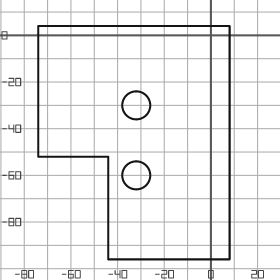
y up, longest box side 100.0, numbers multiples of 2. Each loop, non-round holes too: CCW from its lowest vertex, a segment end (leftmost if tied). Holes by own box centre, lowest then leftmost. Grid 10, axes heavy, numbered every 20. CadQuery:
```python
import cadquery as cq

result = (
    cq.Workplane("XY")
    .moveTo(-44.0, -96.0)
    .lineTo(8.0, -96.0)
    .lineTo(8.0, 4.0)
    .lineTo(-74.0, 4.0)
    .lineTo(-74.0, -52.0)
    .lineTo(-44.0, -52.0)
    .close()
    .moveTo(-32.0, -60.0)
    .circle(6.0)
    .moveTo(-32.0, -30.0)
    .circle(6.0)
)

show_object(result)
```